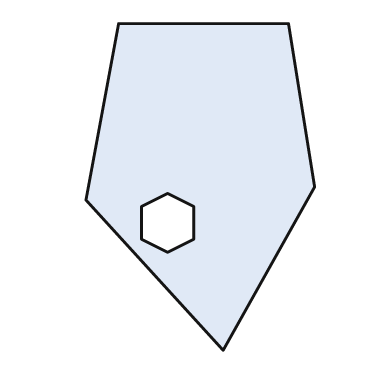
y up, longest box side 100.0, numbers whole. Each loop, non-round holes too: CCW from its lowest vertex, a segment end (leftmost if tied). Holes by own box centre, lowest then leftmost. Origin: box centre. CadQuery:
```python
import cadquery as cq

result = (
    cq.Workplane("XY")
    .moveTo(7.0, -50.0)
    .lineTo(35.0, 0.0)
    .lineTo(27.0, 50.0)
    .lineTo(-25.0, 50.0)
    .lineTo(-35.0, -4.0)
    .close()
    .moveTo(-10.0, -20.0)
    .lineTo(-2.0, -16.0)
    .lineTo(-2.0, -6.0)
    .lineTo(-10.0, -2.0)
    .lineTo(-18.0, -6.0)
    .lineTo(-18.0, -16.0)
    .close()
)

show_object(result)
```